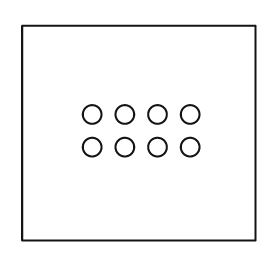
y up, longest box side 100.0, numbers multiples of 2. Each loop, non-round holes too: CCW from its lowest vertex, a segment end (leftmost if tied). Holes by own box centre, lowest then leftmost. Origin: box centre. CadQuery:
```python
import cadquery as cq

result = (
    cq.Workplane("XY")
    .moveTo(-50.0, -46.0)
    .lineTo(50.0, -46.0)
    .lineTo(50.0, 46.0)
    .lineTo(-50.0, 46.0)
    .close()
    .moveTo(-20.0, -6.0)
    .circle(4.0)
    .moveTo(-6.0, -6.0)
    .circle(4.0)
    .moveTo(8.0, -6.0)
    .circle(4.0)
    .moveTo(22.0, -6.0)
    .circle(4.0)
    .moveTo(-20.0, 8.0)
    .circle(4.0)
    .moveTo(-6.0, 8.0)
    .circle(4.0)
    .moveTo(8.0, 8.0)
    .circle(4.0)
    .moveTo(22.0, 8.0)
    .circle(4.0)
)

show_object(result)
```